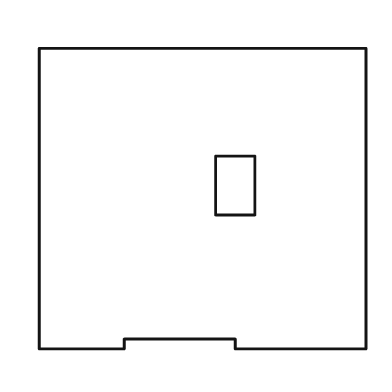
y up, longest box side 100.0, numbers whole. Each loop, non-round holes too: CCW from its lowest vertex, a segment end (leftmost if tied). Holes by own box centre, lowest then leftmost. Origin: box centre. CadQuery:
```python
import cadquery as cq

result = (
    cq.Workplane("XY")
    .moveTo(-50.0, -46.0)
    .lineTo(-24.0, -46.0)
    .lineTo(-24.0, -43.0)
    .lineTo(10.0, -43.0)
    .lineTo(10.0, -46.0)
    .lineTo(50.0, -46.0)
    .lineTo(50.0, 46.0)
    .lineTo(-50.0, 46.0)
    .close()
    .moveTo(4.0, -5.0)
    .lineTo(16.0, -5.0)
    .lineTo(16.0, 13.0)
    .lineTo(4.0, 13.0)
    .close()
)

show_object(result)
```